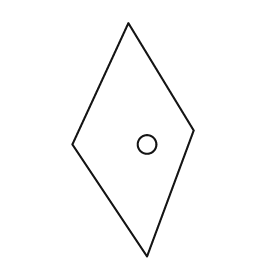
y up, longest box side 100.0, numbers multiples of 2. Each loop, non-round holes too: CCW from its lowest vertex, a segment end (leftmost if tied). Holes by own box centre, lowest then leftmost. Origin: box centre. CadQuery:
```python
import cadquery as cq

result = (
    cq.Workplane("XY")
    .moveTo(6.0, -50.0)
    .lineTo(26.0, 4.0)
    .lineTo(-2.0, 50.0)
    .lineTo(-26.0, -2.0)
    .close()
    .moveTo(6.0, -2.0)
    .circle(4.0)
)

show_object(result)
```